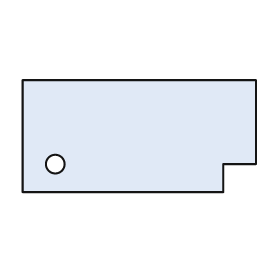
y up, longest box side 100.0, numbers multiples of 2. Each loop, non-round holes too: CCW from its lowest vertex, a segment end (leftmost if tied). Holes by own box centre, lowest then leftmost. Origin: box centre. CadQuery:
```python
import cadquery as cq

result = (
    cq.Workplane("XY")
    .moveTo(-50.0, -24.0)
    .lineTo(36.0, -24.0)
    .lineTo(36.0, -12.0)
    .lineTo(50.0, -12.0)
    .lineTo(50.0, 24.0)
    .lineTo(-50.0, 24.0)
    .close()
    .moveTo(-36.0, -12.0)
    .circle(4.0)
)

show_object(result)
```